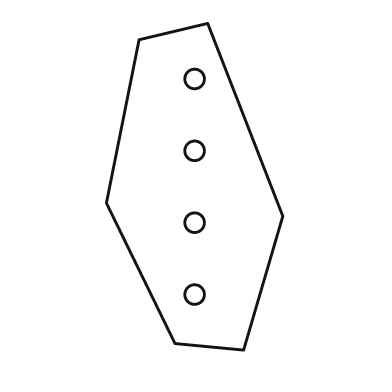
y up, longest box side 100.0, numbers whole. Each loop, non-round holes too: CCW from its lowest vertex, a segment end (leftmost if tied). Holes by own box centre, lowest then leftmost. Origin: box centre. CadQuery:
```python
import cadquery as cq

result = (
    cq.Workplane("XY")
    .moveTo(15.0, -50.0)
    .lineTo(27.0, -9.0)
    .lineTo(4.0, 50.0)
    .lineTo(-17.0, 45.0)
    .lineTo(-27.0, -5.0)
    .lineTo(-6.0, -48.0)
    .close()
    .moveTo(0.0, -33.0)
    .circle(3.0)
    .moveTo(0.0, -11.0)
    .circle(3.0)
    .moveTo(0.0, 11.0)
    .circle(3.0)
    .moveTo(0.0, 33.0)
    .circle(3.0)
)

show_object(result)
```